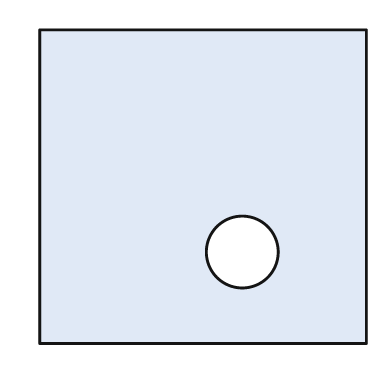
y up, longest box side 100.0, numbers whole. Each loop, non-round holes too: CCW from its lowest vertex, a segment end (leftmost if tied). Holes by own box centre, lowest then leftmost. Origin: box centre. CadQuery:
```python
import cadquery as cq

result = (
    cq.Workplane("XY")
    .moveTo(-50.0, -48.0)
    .lineTo(50.0, -48.0)
    .lineTo(50.0, 48.0)
    .lineTo(-50.0, 48.0)
    .close()
    .moveTo(12.0, -20.0)
    .circle(11.0)
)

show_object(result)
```